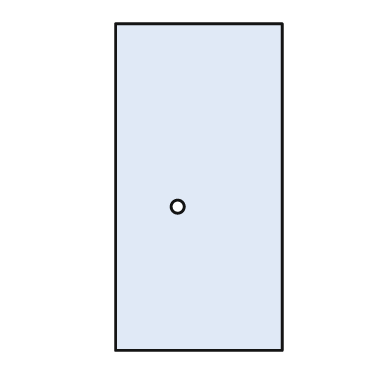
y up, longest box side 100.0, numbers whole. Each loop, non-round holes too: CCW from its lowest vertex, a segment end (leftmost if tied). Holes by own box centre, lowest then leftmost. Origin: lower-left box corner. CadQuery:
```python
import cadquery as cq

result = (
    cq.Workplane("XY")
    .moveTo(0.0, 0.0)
    .lineTo(51.0, 0.0)
    .lineTo(51.0, 100.0)
    .lineTo(0.0, 100.0)
    .close()
    .moveTo(19.0, 44.0)
    .circle(2.0)
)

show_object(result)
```